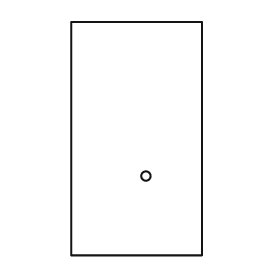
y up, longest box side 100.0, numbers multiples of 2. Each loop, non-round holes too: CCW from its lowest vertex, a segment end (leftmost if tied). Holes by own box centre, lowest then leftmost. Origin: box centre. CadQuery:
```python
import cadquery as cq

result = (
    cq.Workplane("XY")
    .moveTo(-28.0, -50.0)
    .lineTo(28.0, -50.0)
    .lineTo(28.0, 50.0)
    .lineTo(-28.0, 50.0)
    .close()
    .moveTo(4.0, -16.0)
    .circle(2.0)
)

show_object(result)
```